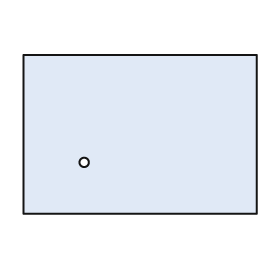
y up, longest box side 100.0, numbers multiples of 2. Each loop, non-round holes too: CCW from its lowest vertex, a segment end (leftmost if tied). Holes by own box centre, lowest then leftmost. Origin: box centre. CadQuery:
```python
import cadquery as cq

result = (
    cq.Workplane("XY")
    .moveTo(-50.0, -34.0)
    .lineTo(50.0, -34.0)
    .lineTo(50.0, 34.0)
    .lineTo(-50.0, 34.0)
    .close()
    .moveTo(-24.0, -12.0)
    .circle(2.0)
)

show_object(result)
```